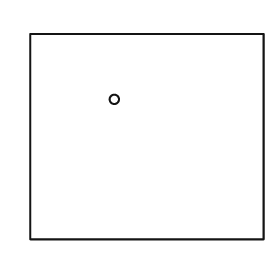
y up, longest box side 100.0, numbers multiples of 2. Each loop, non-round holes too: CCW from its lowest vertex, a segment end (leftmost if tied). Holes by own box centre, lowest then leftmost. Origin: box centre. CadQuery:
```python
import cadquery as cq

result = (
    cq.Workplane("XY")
    .moveTo(-50.0, -44.0)
    .lineTo(50.0, -44.0)
    .lineTo(50.0, 44.0)
    .lineTo(-50.0, 44.0)
    .close()
    .moveTo(-14.0, 16.0)
    .circle(2.0)
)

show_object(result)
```